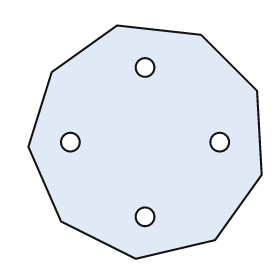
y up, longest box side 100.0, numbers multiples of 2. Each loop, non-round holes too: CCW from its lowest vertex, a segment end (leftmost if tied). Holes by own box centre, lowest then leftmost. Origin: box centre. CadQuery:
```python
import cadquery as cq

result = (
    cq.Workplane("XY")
    .moveTo(-4.0, -50.0)
    .lineTo(30.0, -42.0)
    .lineTo(50.0, -14.0)
    .lineTo(48.0, 22.0)
    .lineTo(24.0, 46.0)
    .lineTo(-12.0, 50.0)
    .lineTo(-40.0, 30.0)
    .lineTo(-50.0, -2.0)
    .lineTo(-36.0, -34.0)
    .close()
    .moveTo(0.0, -32.0)
    .circle(4.0)
    .moveTo(-32.0, 0.0)
    .circle(4.0)
    .moveTo(32.0, 0.0)
    .circle(4.0)
    .moveTo(0.0, 32.0)
    .circle(4.0)
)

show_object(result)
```